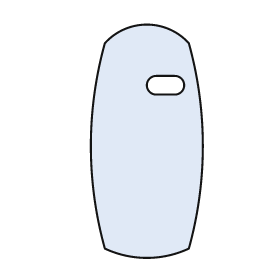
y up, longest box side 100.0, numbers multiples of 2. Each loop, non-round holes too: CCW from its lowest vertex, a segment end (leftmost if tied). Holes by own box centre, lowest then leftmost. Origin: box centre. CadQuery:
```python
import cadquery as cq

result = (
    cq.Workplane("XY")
    .moveTo(-18.0, -46.0)
    .threePointArc((0.0, -50.0), (18.0, -46.0))
    .threePointArc((24.0, -2.0), (18.0, 42.0))
    .threePointArc((0.0, 50.0), (-18.0, 42.0))
    .threePointArc((-24.0, -2.0), (-18.0, -46.0))
    .close()
    .moveTo(4.0, 20.0)
    .lineTo(12.0, 20.0)
    .threePointArc((16.0, 24.0), (12.0, 28.0))
    .lineTo(4.0, 28.0)
    .threePointArc((0.0, 24.0), (4.0, 20.0))
    .close()
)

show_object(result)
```